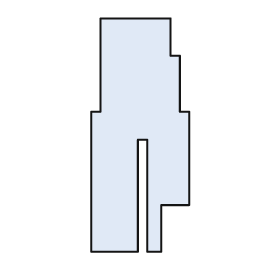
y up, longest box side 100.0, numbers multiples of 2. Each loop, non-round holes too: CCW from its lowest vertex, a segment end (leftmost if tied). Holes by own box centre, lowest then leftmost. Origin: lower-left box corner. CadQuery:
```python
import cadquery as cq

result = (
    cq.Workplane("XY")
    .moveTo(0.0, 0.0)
    .lineTo(20.0, 0.0)
    .lineTo(20.0, 48.0)
    .lineTo(24.0, 48.0)
    .lineTo(24.0, 0.0)
    .lineTo(30.0, 0.0)
    .lineTo(30.0, 20.0)
    .lineTo(42.0, 20.0)
    .lineTo(42.0, 60.0)
    .lineTo(38.0, 60.0)
    .lineTo(38.0, 84.0)
    .lineTo(34.0, 84.0)
    .lineTo(34.0, 100.0)
    .lineTo(4.0, 100.0)
    .lineTo(4.0, 60.0)
    .lineTo(0.0, 60.0)
    .close()
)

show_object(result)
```